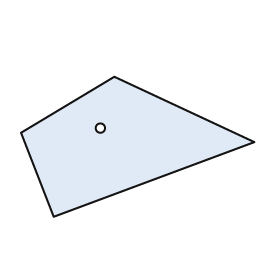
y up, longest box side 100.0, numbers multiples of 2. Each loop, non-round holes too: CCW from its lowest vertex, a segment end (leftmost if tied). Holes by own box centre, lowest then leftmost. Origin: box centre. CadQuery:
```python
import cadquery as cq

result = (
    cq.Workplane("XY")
    .moveTo(-36.0, -30.0)
    .lineTo(50.0, 2.0)
    .lineTo(-10.0, 30.0)
    .lineTo(-50.0, 6.0)
    .close()
    .moveTo(-16.0, 8.0)
    .circle(2.0)
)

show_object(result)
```